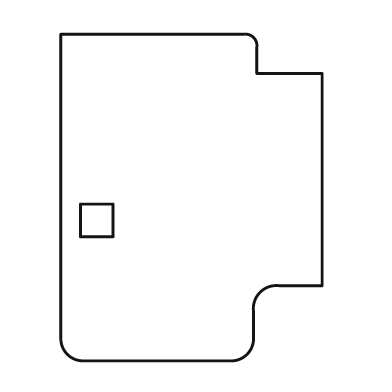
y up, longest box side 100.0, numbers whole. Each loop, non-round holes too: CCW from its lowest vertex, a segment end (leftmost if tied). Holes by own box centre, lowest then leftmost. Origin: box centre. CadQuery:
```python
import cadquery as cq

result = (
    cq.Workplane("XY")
    .moveTo(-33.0, -50.0)
    .lineTo(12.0, -50.0)
    .threePointArc((17.0, -48.0), (19.0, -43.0))
    .lineTo(19.0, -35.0)
    .threePointArc((21.0, -29.0), (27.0, -27.0))
    .lineTo(40.0, -27.0)
    .lineTo(40.0, 38.0)
    .lineTo(20.0, 38.0)
    .lineTo(20.0, 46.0)
    .threePointArc((19.0, 49.0), (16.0, 50.0))
    .lineTo(-40.0, 50.0)
    .lineTo(-40.0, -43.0)
    .threePointArc((-38.0, -48.0), (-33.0, -50.0))
    .close()
    .moveTo(-34.0, -12.0)
    .lineTo(-24.0, -12.0)
    .lineTo(-24.0, -2.0)
    .lineTo(-34.0, -2.0)
    .close()
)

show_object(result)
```